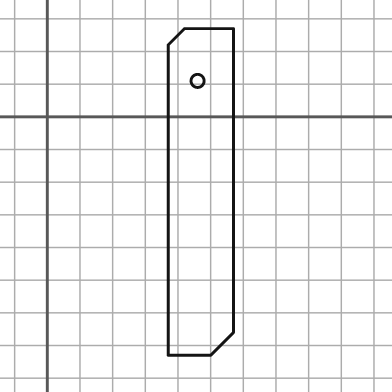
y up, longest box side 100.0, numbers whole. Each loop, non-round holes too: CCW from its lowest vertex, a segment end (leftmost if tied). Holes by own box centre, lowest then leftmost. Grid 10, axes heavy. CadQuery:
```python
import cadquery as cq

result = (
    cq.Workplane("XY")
    .moveTo(37.0, -73.0)
    .lineTo(50.0, -73.0)
    .lineTo(57.0, -66.0)
    .lineTo(57.0, 27.0)
    .lineTo(42.0, 27.0)
    .lineTo(37.0, 22.0)
    .close()
    .moveTo(46.0, 11.0)
    .circle(2.0)
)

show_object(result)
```